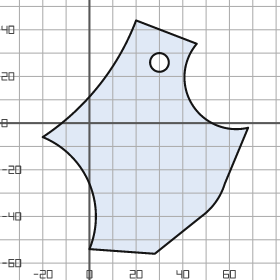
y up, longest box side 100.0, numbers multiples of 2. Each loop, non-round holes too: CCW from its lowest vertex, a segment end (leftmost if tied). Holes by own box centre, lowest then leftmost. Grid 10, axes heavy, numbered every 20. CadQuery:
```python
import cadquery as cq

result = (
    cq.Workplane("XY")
    .moveTo(28.0, -56.0)
    .lineTo(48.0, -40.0)
    .threePointArc((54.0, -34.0), (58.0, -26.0))
    .lineTo(68.0, -2.0)
    .threePointArc((44.0, 8.0), (46.0, 34.0))
    .lineTo(20.0, 44.0)
    .threePointArc((4.0, 16.0), (-20.0, -6.0))
    .threePointArc((0.0, -26.0), (0.0, -54.0))
    .close()
    .moveTo(30.0, 26.0)
    .circle(4.0)
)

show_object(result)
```